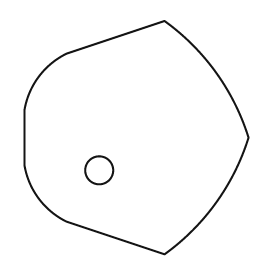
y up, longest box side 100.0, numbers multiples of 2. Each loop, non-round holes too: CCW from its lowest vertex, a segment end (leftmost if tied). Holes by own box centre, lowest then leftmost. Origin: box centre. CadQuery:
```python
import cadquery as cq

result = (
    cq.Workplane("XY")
    .moveTo(12.0, -50.0)
    .threePointArc((34.0, -28.0), (48.0, 0.0))
    .threePointArc((34.0, 28.0), (12.0, 50.0))
    .lineTo(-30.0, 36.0)
    .threePointArc((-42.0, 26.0), (-48.0, 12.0))
    .lineTo(-48.0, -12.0)
    .threePointArc((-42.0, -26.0), (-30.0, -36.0))
    .close()
    .moveTo(-16.0, -14.0)
    .circle(6.0)
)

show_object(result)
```